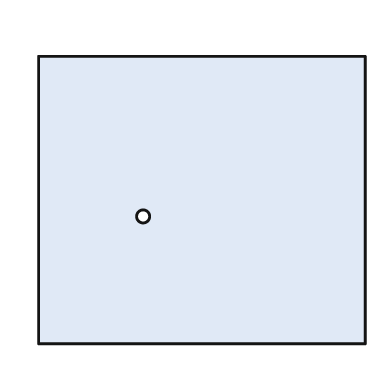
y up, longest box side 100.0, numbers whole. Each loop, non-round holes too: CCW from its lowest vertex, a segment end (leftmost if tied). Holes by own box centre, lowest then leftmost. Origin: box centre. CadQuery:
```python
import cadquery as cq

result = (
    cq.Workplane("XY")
    .moveTo(-50.0, -44.0)
    .lineTo(50.0, -44.0)
    .lineTo(50.0, 44.0)
    .lineTo(-50.0, 44.0)
    .close()
    .moveTo(-18.0, -5.0)
    .circle(2.0)
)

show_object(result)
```